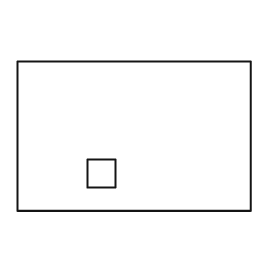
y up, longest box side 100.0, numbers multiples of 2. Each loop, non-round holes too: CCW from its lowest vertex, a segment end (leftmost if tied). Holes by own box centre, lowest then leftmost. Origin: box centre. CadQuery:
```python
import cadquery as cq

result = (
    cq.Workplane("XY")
    .moveTo(-50.0, -32.0)
    .lineTo(50.0, -32.0)
    .lineTo(50.0, 32.0)
    .lineTo(-50.0, 32.0)
    .close()
    .moveTo(-20.0, -22.0)
    .lineTo(-8.0, -22.0)
    .lineTo(-8.0, -10.0)
    .lineTo(-20.0, -10.0)
    .close()
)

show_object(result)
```